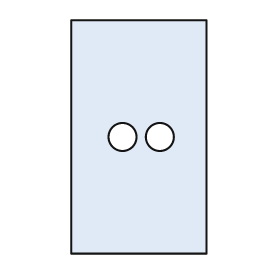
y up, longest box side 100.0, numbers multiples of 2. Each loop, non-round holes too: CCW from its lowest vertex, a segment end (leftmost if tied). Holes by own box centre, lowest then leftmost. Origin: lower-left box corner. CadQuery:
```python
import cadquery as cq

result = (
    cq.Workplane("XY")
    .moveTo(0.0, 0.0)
    .lineTo(58.0, 0.0)
    .lineTo(58.0, 100.0)
    .lineTo(0.0, 100.0)
    .close()
    .moveTo(22.0, 50.0)
    .circle(6.0)
    .moveTo(38.0, 50.0)
    .circle(6.0)
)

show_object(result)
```